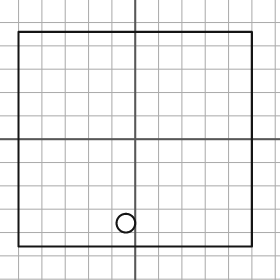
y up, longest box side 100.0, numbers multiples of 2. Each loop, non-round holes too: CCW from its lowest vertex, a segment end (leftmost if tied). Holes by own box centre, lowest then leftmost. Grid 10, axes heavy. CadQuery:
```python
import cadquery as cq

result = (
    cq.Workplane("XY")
    .moveTo(-50.0, -46.0)
    .lineTo(50.0, -46.0)
    .lineTo(50.0, 46.0)
    .lineTo(-50.0, 46.0)
    .close()
    .moveTo(-4.0, -36.0)
    .circle(4.0)
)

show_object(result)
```